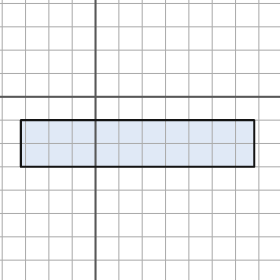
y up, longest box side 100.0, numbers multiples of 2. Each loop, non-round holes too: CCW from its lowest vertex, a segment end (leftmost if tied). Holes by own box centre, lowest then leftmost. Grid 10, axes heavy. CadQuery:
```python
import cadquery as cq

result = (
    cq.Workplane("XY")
    .moveTo(-32.0, -30.0)
    .lineTo(68.0, -30.0)
    .lineTo(68.0, -10.0)
    .lineTo(-32.0, -10.0)
    .close()
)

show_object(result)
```